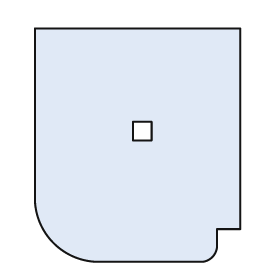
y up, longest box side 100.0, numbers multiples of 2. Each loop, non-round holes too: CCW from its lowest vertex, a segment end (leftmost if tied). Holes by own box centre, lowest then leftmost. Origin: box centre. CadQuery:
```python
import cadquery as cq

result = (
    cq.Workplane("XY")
    .moveTo(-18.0, -50.0)
    .lineTo(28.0, -50.0)
    .threePointArc((32.0, -48.0), (34.0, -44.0))
    .lineTo(34.0, -36.0)
    .lineTo(44.0, -36.0)
    .lineTo(44.0, 50.0)
    .lineTo(-44.0, 50.0)
    .lineTo(-44.0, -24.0)
    .threePointArc((-36.0, -42.0), (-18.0, -50.0))
    .close()
    .moveTo(-2.0, 2.0)
    .lineTo(6.0, 2.0)
    .lineTo(6.0, 10.0)
    .lineTo(-2.0, 10.0)
    .close()
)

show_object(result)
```